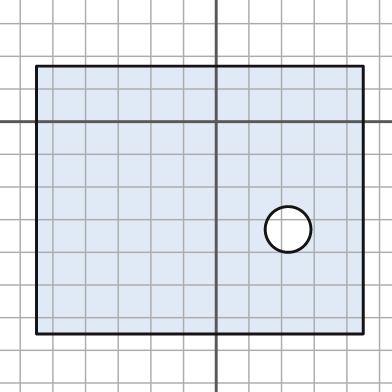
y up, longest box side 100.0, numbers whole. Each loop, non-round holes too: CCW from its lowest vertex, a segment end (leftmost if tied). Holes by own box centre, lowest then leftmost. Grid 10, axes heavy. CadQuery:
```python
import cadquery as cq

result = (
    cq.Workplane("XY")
    .moveTo(-55.0, -65.0)
    .lineTo(45.0, -65.0)
    .lineTo(45.0, 17.0)
    .lineTo(-55.0, 17.0)
    .close()
    .moveTo(22.0, -33.0)
    .circle(7.0)
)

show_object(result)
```